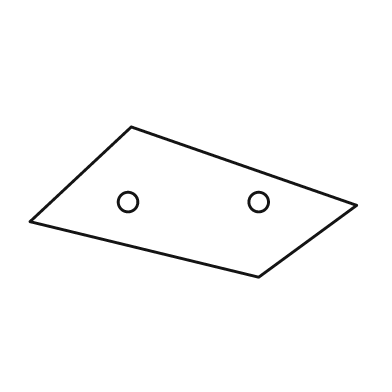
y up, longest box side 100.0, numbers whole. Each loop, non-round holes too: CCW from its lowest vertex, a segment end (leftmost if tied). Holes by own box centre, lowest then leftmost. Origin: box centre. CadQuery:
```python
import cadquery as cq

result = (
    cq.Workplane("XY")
    .moveTo(20.0, -23.0)
    .lineTo(50.0, -1.0)
    .lineTo(-19.0, 23.0)
    .lineTo(-50.0, -6.0)
    .close()
    .moveTo(-20.0, 0.0)
    .circle(3.0)
    .moveTo(20.0, 0.0)
    .circle(3.0)
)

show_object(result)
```